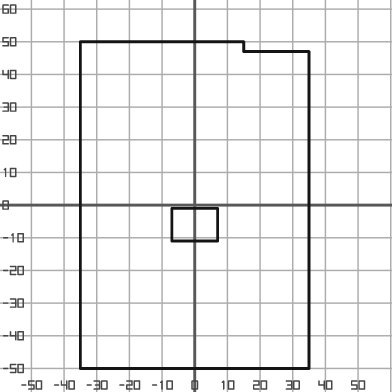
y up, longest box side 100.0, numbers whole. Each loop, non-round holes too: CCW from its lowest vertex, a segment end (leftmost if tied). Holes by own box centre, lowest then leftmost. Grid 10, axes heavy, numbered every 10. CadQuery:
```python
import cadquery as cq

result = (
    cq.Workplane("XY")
    .moveTo(-35.0, -50.0)
    .lineTo(35.0, -50.0)
    .lineTo(35.0, 47.0)
    .lineTo(15.0, 47.0)
    .lineTo(15.0, 50.0)
    .lineTo(-35.0, 50.0)
    .close()
    .moveTo(-7.0, -11.0)
    .lineTo(7.0, -11.0)
    .lineTo(7.0, -1.0)
    .lineTo(-7.0, -1.0)
    .close()
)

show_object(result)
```